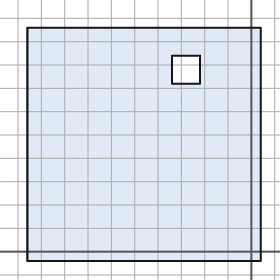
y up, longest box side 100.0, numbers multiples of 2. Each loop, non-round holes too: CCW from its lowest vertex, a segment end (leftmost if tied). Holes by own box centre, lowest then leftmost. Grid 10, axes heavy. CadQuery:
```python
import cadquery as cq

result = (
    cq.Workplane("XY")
    .moveTo(-96.0, -4.0)
    .lineTo(4.0, -4.0)
    .lineTo(4.0, 96.0)
    .lineTo(-96.0, 96.0)
    .close()
    .moveTo(-34.0, 72.0)
    .lineTo(-22.0, 72.0)
    .lineTo(-22.0, 84.0)
    .lineTo(-34.0, 84.0)
    .close()
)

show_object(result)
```